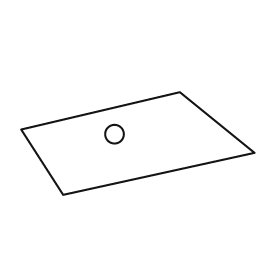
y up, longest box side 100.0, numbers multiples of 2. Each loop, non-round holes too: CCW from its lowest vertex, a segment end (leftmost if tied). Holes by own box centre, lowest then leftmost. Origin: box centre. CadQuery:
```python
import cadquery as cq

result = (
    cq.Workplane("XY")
    .moveTo(-32.0, -22.0)
    .lineTo(50.0, -4.0)
    .lineTo(18.0, 22.0)
    .lineTo(-50.0, 6.0)
    .close()
    .moveTo(-10.0, 4.0)
    .circle(4.0)
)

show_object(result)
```